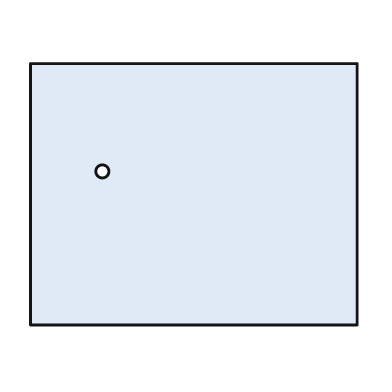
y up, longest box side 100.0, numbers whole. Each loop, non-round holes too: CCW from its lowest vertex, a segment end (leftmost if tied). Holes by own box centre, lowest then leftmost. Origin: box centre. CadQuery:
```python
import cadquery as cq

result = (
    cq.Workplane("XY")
    .moveTo(-50.0, -40.0)
    .lineTo(50.0, -40.0)
    .lineTo(50.0, 40.0)
    .lineTo(-50.0, 40.0)
    .close()
    .moveTo(-28.0, 7.0)
    .circle(2.0)
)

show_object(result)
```